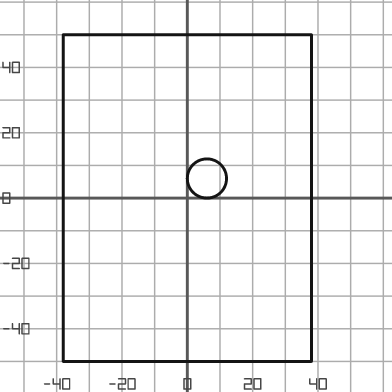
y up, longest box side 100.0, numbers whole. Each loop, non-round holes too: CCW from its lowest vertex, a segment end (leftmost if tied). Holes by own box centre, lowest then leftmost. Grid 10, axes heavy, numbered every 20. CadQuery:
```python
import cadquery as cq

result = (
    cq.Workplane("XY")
    .moveTo(-38.0, -50.0)
    .lineTo(38.0, -50.0)
    .lineTo(38.0, 50.0)
    .lineTo(-38.0, 50.0)
    .close()
    .moveTo(6.0, 6.0)
    .circle(6.0)
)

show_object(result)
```